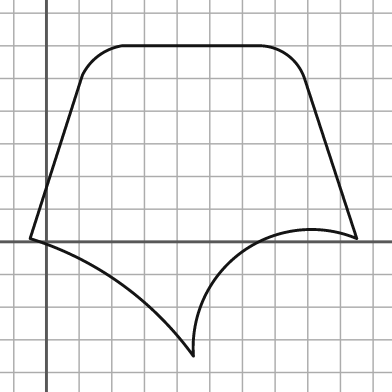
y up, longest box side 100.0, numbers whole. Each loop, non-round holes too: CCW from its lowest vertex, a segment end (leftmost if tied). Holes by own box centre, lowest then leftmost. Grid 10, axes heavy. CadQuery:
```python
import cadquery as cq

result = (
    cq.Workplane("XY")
    .moveTo(45.0, -35.0)
    .threePointArc((60.0, -3.0), (95.0, 1.0))
    .lineTo(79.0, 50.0)
    .threePointArc((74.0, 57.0), (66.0, 60.0))
    .lineTo(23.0, 60.0)
    .threePointArc((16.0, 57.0), (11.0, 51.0))
    .lineTo(-5.0, 1.0)
    .threePointArc((23.0, -13.0), (45.0, -35.0))
    .close()
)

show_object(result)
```